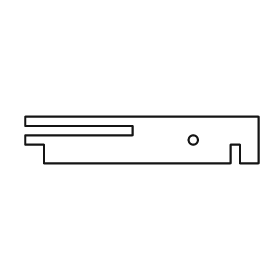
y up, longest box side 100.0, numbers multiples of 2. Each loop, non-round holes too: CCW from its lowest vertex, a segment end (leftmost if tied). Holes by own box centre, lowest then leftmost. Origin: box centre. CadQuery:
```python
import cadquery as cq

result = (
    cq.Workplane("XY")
    .moveTo(-42.0, -10.0)
    .lineTo(38.0, -10.0)
    .lineTo(38.0, -2.0)
    .lineTo(42.0, -2.0)
    .lineTo(42.0, -10.0)
    .lineTo(50.0, -10.0)
    .lineTo(50.0, 10.0)
    .lineTo(-50.0, 10.0)
    .lineTo(-50.0, 6.0)
    .lineTo(-4.0, 6.0)
    .lineTo(-4.0, 2.0)
    .lineTo(-50.0, 2.0)
    .lineTo(-50.0, -2.0)
    .lineTo(-42.0, -2.0)
    .close()
    .moveTo(22.0, 0.0)
    .circle(2.0)
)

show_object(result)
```